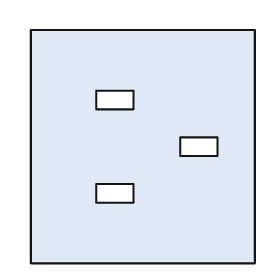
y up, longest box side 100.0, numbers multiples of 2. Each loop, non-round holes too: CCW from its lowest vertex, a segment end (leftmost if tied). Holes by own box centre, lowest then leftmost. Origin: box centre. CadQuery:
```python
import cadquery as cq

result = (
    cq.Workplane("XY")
    .moveTo(-48.0, -50.0)
    .lineTo(48.0, -50.0)
    .lineTo(48.0, 50.0)
    .lineTo(-48.0, 50.0)
    .close()
    .moveTo(-20.0, -24.0)
    .lineTo(-4.0, -24.0)
    .lineTo(-4.0, -16.0)
    .lineTo(-20.0, -16.0)
    .close()
    .moveTo(16.0, -4.0)
    .lineTo(32.0, -4.0)
    .lineTo(32.0, 4.0)
    .lineTo(16.0, 4.0)
    .close()
    .moveTo(-20.0, 16.0)
    .lineTo(-4.0, 16.0)
    .lineTo(-4.0, 24.0)
    .lineTo(-20.0, 24.0)
    .close()
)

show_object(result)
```